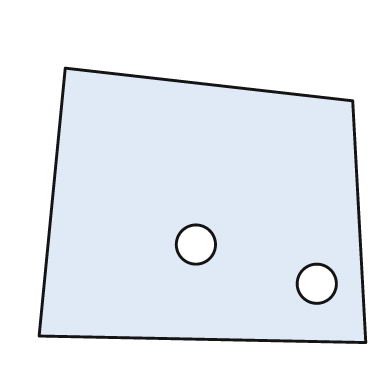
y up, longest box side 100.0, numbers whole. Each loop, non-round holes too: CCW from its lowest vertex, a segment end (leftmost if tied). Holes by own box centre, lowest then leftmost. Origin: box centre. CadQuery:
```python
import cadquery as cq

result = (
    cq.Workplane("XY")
    .moveTo(50.0, -42.0)
    .lineTo(46.0, 32.0)
    .lineTo(-42.0, 42.0)
    .lineTo(-50.0, -40.0)
    .close()
    .moveTo(35.0, -24.0)
    .circle(6.0)
    .moveTo(-2.0, -12.0)
    .circle(6.0)
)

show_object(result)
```